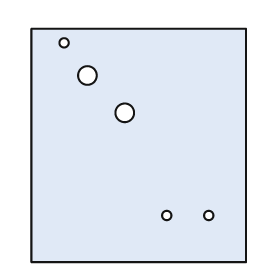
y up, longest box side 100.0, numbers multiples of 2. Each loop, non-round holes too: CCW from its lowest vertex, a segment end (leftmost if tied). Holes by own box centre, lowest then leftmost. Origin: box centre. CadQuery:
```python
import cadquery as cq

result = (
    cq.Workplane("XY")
    .moveTo(-46.0, -50.0)
    .lineTo(46.0, -50.0)
    .lineTo(46.0, 50.0)
    .lineTo(-46.0, 50.0)
    .close()
    .moveTo(12.0, -30.0)
    .circle(2.0)
    .moveTo(30.0, -30.0)
    .circle(2.0)
    .moveTo(-6.0, 14.0)
    .circle(4.0)
    .moveTo(-22.0, 30.0)
    .circle(4.0)
    .moveTo(-32.0, 44.0)
    .circle(2.0)
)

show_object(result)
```